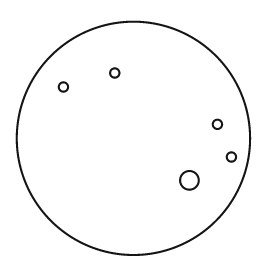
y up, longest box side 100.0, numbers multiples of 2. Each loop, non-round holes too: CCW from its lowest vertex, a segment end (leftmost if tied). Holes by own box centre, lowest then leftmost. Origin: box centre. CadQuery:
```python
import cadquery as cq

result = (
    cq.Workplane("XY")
    .moveTo(0.0, 0.0)
    .circle(50.0)
    .moveTo(24.0, -18.0)
    .circle(4.0)
    .moveTo(42.0, -8.0)
    .circle(2.0)
    .moveTo(36.0, 6.0)
    .circle(2.0)
    .moveTo(-30.0, 22.0)
    .circle(2.0)
    .moveTo(-8.0, 28.0)
    .circle(2.0)
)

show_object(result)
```